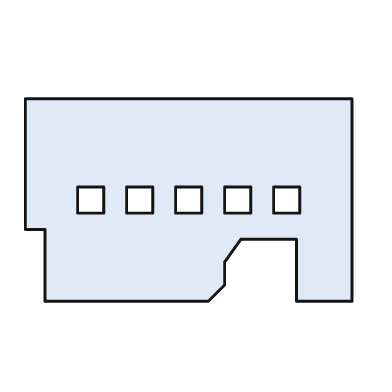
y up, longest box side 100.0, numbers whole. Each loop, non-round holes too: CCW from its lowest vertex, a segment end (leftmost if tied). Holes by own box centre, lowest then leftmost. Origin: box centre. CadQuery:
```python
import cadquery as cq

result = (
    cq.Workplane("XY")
    .moveTo(-44.0, -31.0)
    .lineTo(6.0, -31.0)
    .lineTo(11.0, -26.0)
    .lineTo(11.0, -19.0)
    .lineTo(16.0, -12.0)
    .lineTo(33.0, -12.0)
    .lineTo(33.0, -31.0)
    .lineTo(50.0, -31.0)
    .lineTo(50.0, 31.0)
    .lineTo(-50.0, 31.0)
    .lineTo(-50.0, -9.0)
    .lineTo(-44.0, -9.0)
    .close()
    .moveTo(-34.0, -4.0)
    .lineTo(-26.0, -4.0)
    .lineTo(-26.0, 4.0)
    .lineTo(-34.0, 4.0)
    .close()
    .moveTo(-19.0, -4.0)
    .lineTo(-11.0, -4.0)
    .lineTo(-11.0, 4.0)
    .lineTo(-19.0, 4.0)
    .close()
    .moveTo(-4.0, -4.0)
    .lineTo(4.0, -4.0)
    .lineTo(4.0, 4.0)
    .lineTo(-4.0, 4.0)
    .close()
    .moveTo(11.0, -4.0)
    .lineTo(19.0, -4.0)
    .lineTo(19.0, 4.0)
    .lineTo(11.0, 4.0)
    .close()
    .moveTo(26.0, -4.0)
    .lineTo(34.0, -4.0)
    .lineTo(34.0, 4.0)
    .lineTo(26.0, 4.0)
    .close()
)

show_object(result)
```